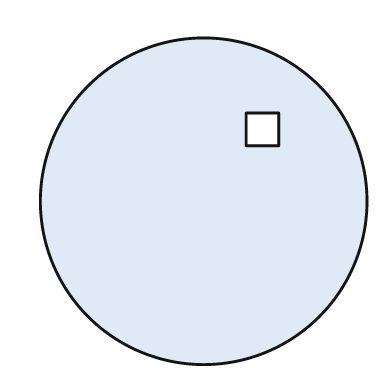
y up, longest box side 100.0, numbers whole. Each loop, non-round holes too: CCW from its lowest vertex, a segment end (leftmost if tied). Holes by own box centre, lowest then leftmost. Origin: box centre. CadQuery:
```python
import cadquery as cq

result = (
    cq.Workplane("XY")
    .moveTo(0.0, 0.0)
    .circle(50.0)
    .moveTo(13.0, 17.0)
    .lineTo(23.0, 17.0)
    .lineTo(23.0, 27.0)
    .lineTo(13.0, 27.0)
    .close()
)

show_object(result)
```